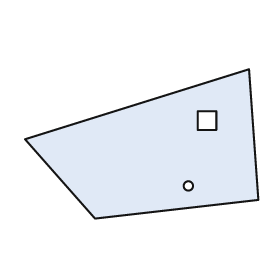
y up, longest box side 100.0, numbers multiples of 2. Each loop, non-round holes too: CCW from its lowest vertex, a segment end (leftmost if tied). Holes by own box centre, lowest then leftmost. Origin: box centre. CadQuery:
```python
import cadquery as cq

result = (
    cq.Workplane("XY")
    .moveTo(-20.0, -32.0)
    .lineTo(50.0, -24.0)
    .lineTo(46.0, 32.0)
    .lineTo(-50.0, 2.0)
    .close()
    .moveTo(20.0, -18.0)
    .circle(2.0)
    .moveTo(24.0, 6.0)
    .lineTo(32.0, 6.0)
    .lineTo(32.0, 14.0)
    .lineTo(24.0, 14.0)
    .close()
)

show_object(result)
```